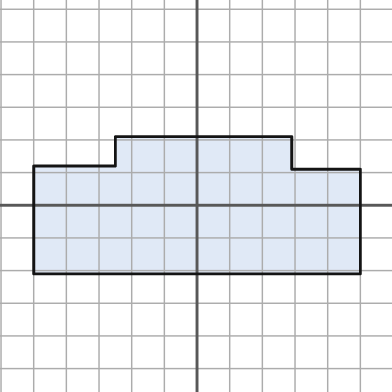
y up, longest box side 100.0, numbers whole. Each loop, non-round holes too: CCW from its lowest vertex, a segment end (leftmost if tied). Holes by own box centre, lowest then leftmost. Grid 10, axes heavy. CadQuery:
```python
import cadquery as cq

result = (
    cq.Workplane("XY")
    .moveTo(-50.0, -21.0)
    .lineTo(50.0, -21.0)
    .lineTo(50.0, 11.0)
    .lineTo(29.0, 11.0)
    .lineTo(29.0, 21.0)
    .lineTo(-25.0, 21.0)
    .lineTo(-25.0, 12.0)
    .lineTo(-50.0, 12.0)
    .close()
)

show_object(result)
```